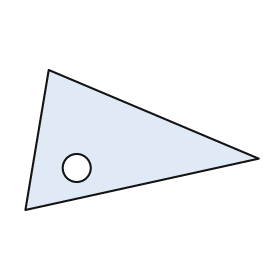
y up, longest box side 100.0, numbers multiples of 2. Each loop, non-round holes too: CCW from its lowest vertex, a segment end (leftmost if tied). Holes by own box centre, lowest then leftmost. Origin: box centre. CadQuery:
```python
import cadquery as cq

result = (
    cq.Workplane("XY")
    .moveTo(-50.0, -30.0)
    .lineTo(50.0, -8.0)
    .lineTo(-40.0, 30.0)
    .close()
    .moveTo(-28.0, -12.0)
    .circle(6.0)
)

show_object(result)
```